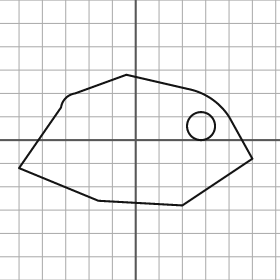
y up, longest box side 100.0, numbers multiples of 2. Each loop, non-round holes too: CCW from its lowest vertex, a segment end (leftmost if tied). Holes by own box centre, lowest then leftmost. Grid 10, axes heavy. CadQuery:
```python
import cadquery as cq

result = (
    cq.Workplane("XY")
    .moveTo(20.0, -28.0)
    .lineTo(50.0, -8.0)
    .lineTo(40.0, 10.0)
    .threePointArc((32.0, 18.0), (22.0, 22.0))
    .lineTo(-4.0, 28.0)
    .lineTo(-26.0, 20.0)
    .threePointArc((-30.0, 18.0), (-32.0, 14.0))
    .lineTo(-50.0, -12.0)
    .lineTo(-16.0, -26.0)
    .close()
    .moveTo(28.0, 6.0)
    .circle(6.0)
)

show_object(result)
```